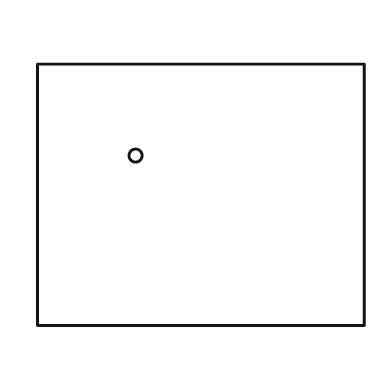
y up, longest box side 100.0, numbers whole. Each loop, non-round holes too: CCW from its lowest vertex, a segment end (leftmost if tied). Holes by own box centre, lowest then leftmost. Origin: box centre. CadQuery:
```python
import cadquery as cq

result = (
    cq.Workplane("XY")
    .moveTo(-50.0, -40.0)
    .lineTo(50.0, -40.0)
    .lineTo(50.0, 40.0)
    .lineTo(-50.0, 40.0)
    .close()
    .moveTo(-20.0, 12.0)
    .circle(2.0)
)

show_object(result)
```